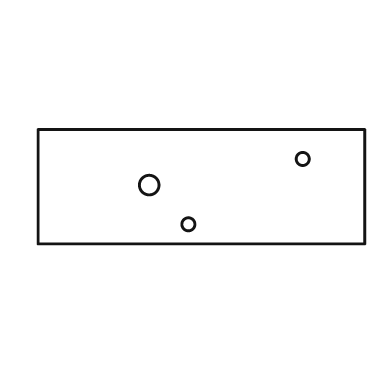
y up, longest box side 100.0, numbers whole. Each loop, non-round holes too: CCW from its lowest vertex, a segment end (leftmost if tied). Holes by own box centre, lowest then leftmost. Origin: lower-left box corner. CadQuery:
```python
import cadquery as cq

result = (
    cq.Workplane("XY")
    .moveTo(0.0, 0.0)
    .lineTo(100.0, 0.0)
    .lineTo(100.0, 35.0)
    .lineTo(0.0, 35.0)
    .close()
    .moveTo(46.0, 6.0)
    .circle(2.0)
    .moveTo(34.0, 18.0)
    .circle(3.0)
    .moveTo(81.0, 26.0)
    .circle(2.0)
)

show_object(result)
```